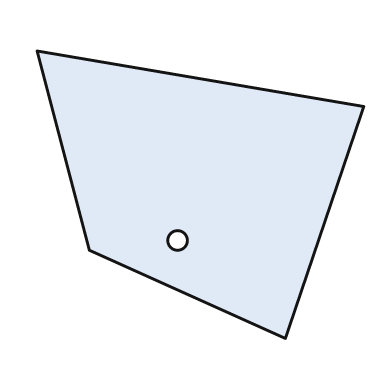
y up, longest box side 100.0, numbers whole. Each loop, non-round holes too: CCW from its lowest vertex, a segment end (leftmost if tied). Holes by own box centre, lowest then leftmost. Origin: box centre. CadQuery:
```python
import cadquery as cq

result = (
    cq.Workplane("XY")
    .moveTo(26.0, -44.0)
    .lineTo(50.0, 27.0)
    .lineTo(-50.0, 44.0)
    .lineTo(-34.0, -17.0)
    .close()
    .moveTo(-7.0, -14.0)
    .circle(3.0)
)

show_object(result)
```